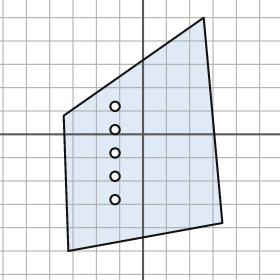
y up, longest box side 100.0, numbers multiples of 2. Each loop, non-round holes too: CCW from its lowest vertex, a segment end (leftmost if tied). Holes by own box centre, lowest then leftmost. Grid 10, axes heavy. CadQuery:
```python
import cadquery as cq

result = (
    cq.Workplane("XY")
    .moveTo(-32.0, -50.0)
    .lineTo(34.0, -38.0)
    .lineTo(26.0, 50.0)
    .lineTo(-34.0, 8.0)
    .close()
    .moveTo(-12.0, -28.0)
    .circle(2.0)
    .moveTo(-12.0, -18.0)
    .circle(2.0)
    .moveTo(-12.0, -8.0)
    .circle(2.0)
    .moveTo(-12.0, 2.0)
    .circle(2.0)
    .moveTo(-12.0, 12.0)
    .circle(2.0)
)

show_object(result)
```